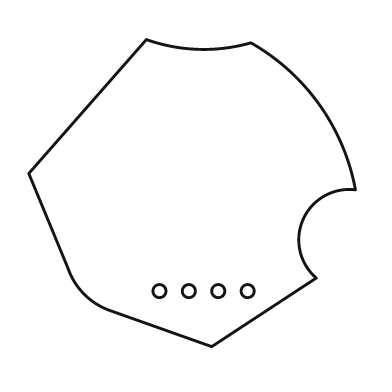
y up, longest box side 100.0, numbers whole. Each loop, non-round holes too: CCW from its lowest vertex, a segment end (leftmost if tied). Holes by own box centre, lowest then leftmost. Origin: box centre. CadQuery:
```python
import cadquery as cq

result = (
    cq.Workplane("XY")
    .moveTo(6.0, -47.0)
    .lineTo(38.0, -26.0)
    .threePointArc((34.0, -8.0), (50.0, 1.0))
    .threePointArc((39.0, 27.0), (18.0, 46.0))
    .threePointArc((2.0, 44.0), (-14.0, 47.0))
    .lineTo(-50.0, 6.0)
    .lineTo(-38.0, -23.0)
    .threePointArc((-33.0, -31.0), (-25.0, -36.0))
    .close()
    .moveTo(-10.0, -30.0)
    .circle(2.0)
    .moveTo(-1.0, -30.0)
    .circle(2.0)
    .moveTo(8.0, -30.0)
    .circle(2.0)
    .moveTo(17.0, -30.0)
    .circle(2.0)
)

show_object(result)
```